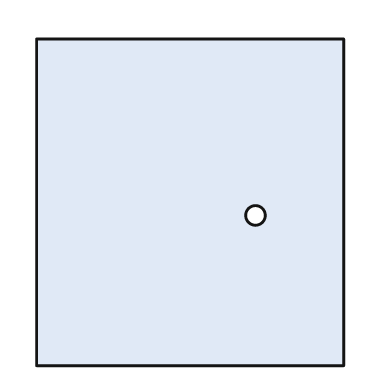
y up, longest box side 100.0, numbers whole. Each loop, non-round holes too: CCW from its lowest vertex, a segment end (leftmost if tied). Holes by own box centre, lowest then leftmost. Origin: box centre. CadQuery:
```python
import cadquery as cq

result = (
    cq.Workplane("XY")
    .moveTo(-47.0, -50.0)
    .lineTo(47.0, -50.0)
    .lineTo(47.0, 50.0)
    .lineTo(-47.0, 50.0)
    .close()
    .moveTo(20.0, -4.0)
    .circle(3.0)
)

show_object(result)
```